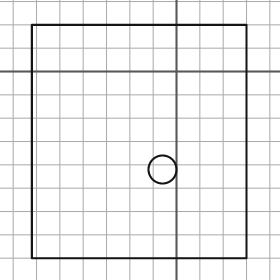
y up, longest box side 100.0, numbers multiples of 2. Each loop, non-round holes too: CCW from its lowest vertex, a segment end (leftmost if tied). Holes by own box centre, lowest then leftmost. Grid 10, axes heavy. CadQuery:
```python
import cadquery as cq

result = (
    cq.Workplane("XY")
    .moveTo(-62.0, -80.0)
    .lineTo(30.0, -80.0)
    .lineTo(30.0, 20.0)
    .lineTo(-62.0, 20.0)
    .close()
    .moveTo(-6.0, -42.0)
    .circle(6.0)
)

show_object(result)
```